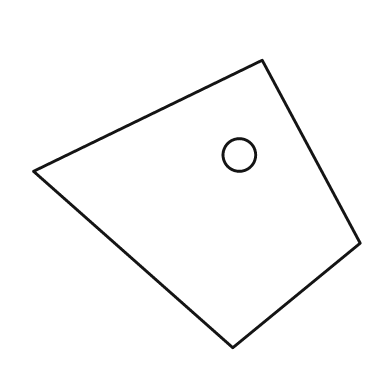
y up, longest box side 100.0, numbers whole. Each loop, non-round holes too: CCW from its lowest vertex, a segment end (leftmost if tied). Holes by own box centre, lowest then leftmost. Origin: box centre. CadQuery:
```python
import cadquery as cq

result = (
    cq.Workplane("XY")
    .moveTo(11.0, -44.0)
    .lineTo(50.0, -12.0)
    .lineTo(20.0, 44.0)
    .lineTo(-50.0, 10.0)
    .close()
    .moveTo(13.0, 15.0)
    .circle(5.0)
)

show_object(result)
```